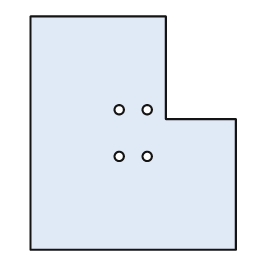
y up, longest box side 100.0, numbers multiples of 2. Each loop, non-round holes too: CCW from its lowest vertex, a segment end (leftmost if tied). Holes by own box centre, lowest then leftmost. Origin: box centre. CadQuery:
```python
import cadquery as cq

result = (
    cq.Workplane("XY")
    .moveTo(-44.0, -50.0)
    .lineTo(44.0, -50.0)
    .lineTo(44.0, 6.0)
    .lineTo(14.0, 6.0)
    .lineTo(14.0, 50.0)
    .lineTo(-44.0, 50.0)
    .close()
    .moveTo(-6.0, -10.0)
    .circle(2.0)
    .moveTo(6.0, -10.0)
    .circle(2.0)
    .moveTo(-6.0, 10.0)
    .circle(2.0)
    .moveTo(6.0, 10.0)
    .circle(2.0)
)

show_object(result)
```